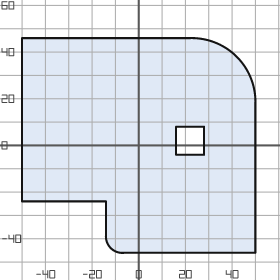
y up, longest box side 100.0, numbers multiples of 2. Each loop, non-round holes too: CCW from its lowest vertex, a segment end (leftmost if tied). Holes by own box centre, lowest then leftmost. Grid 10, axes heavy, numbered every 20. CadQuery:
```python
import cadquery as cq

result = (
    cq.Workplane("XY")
    .moveTo(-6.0, -46.0)
    .lineTo(50.0, -46.0)
    .lineTo(50.0, 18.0)
    .threePointArc((42.0, 38.0), (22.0, 46.0))
    .lineTo(-50.0, 46.0)
    .lineTo(-50.0, -24.0)
    .lineTo(-14.0, -24.0)
    .lineTo(-14.0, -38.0)
    .threePointArc((-12.0, -44.0), (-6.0, -46.0))
    .close()
    .moveTo(16.0, -4.0)
    .lineTo(28.0, -4.0)
    .lineTo(28.0, 8.0)
    .lineTo(16.0, 8.0)
    .close()
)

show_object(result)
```